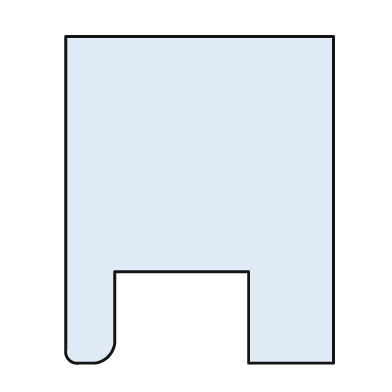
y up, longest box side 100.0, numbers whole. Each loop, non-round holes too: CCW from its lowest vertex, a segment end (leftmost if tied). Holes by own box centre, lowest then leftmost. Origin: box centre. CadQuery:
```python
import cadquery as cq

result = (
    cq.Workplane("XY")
    .moveTo(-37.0, -50.0)
    .lineTo(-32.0, -50.0)
    .threePointArc((-28.0, -48.0), (-26.0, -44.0))
    .lineTo(-26.0, -22.0)
    .lineTo(15.0, -22.0)
    .lineTo(15.0, -50.0)
    .lineTo(41.0, -50.0)
    .lineTo(41.0, 50.0)
    .lineTo(-41.0, 50.0)
    .lineTo(-41.0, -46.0)
    .threePointArc((-40.0, -49.0), (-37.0, -50.0))
    .close()
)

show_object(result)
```